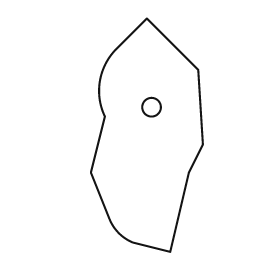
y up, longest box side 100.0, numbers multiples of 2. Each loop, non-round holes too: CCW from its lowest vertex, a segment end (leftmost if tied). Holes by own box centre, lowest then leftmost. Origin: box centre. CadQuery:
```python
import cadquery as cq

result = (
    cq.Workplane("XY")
    .moveTo(10.0, -50.0)
    .lineTo(18.0, -16.0)
    .lineTo(24.0, -4.0)
    .lineTo(22.0, 28.0)
    .lineTo(0.0, 50.0)
    .lineTo(-12.0, 38.0)
    .threePointArc((-20.0, 24.0), (-18.0, 8.0))
    .lineTo(-24.0, -16.0)
    .lineTo(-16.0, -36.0)
    .threePointArc((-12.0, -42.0), (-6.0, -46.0))
    .close()
    .moveTo(2.0, 12.0)
    .circle(4.0)
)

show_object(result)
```